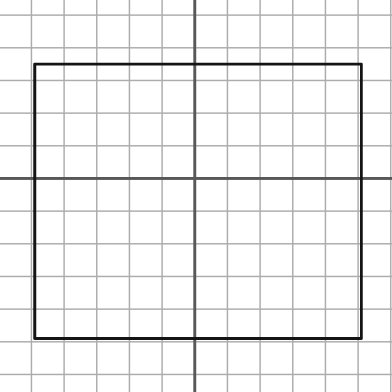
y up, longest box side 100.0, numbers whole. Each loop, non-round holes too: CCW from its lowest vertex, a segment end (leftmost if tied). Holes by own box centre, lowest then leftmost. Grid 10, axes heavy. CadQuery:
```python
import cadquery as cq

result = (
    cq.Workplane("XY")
    .moveTo(-49.0, -49.0)
    .lineTo(51.0, -49.0)
    .lineTo(51.0, 35.0)
    .lineTo(-49.0, 35.0)
    .close()
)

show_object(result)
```